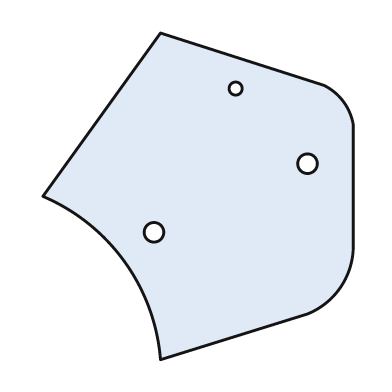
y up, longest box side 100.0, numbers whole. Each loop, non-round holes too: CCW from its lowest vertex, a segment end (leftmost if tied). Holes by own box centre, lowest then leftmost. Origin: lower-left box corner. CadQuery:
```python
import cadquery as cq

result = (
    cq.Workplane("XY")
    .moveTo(36.0, 0.0)
    .lineTo(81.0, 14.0)
    .threePointArc((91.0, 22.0), (95.0, 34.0))
    .lineTo(95.0, 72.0)
    .threePointArc((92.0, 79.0), (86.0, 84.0))
    .lineTo(36.0, 100.0)
    .lineTo(0.0, 50.0)
    .threePointArc((25.0, 30.0), (36.0, 0.0))
    .close()
    .moveTo(34.0, 39.0)
    .circle(3.0)
    .moveTo(81.0, 60.0)
    .circle(3.0)
    .moveTo(59.0, 83.0)
    .circle(2.0)
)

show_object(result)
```